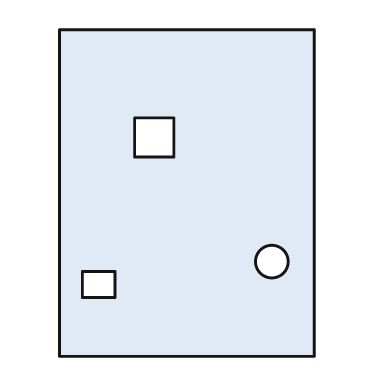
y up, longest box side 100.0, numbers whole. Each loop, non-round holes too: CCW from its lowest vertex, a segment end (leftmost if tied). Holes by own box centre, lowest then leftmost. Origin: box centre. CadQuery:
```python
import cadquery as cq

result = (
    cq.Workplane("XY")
    .moveTo(-39.0, -50.0)
    .lineTo(39.0, -50.0)
    .lineTo(39.0, 50.0)
    .lineTo(-39.0, 50.0)
    .close()
    .moveTo(-32.0, -32.0)
    .lineTo(-22.0, -32.0)
    .lineTo(-22.0, -24.0)
    .lineTo(-32.0, -24.0)
    .close()
    .moveTo(26.0, -21.0)
    .circle(5.0)
    .moveTo(-16.0, 11.0)
    .lineTo(-4.0, 11.0)
    .lineTo(-4.0, 23.0)
    .lineTo(-16.0, 23.0)
    .close()
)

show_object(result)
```